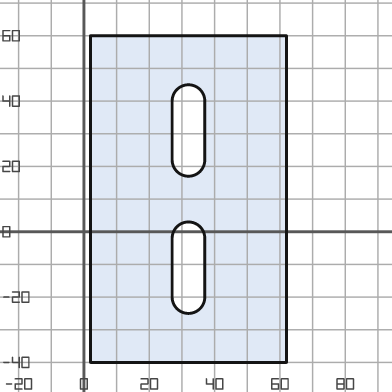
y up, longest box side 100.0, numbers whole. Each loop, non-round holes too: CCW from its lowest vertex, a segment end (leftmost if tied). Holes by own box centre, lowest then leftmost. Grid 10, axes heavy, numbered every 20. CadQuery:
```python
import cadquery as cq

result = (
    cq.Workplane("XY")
    .moveTo(2.0, -40.0)
    .lineTo(62.0, -40.0)
    .lineTo(62.0, 60.0)
    .lineTo(2.0, 60.0)
    .close()
    .moveTo(27.0, -20.0)
    .threePointArc((32.0, -25.0), (37.0, -20.0))
    .lineTo(37.0, -2.0)
    .threePointArc((32.0, 3.0), (27.0, -2.0))
    .close()
    .moveTo(27.0, 22.0)
    .threePointArc((32.0, 17.0), (37.0, 22.0))
    .lineTo(37.0, 40.0)
    .threePointArc((32.0, 45.0), (27.0, 40.0))
    .close()
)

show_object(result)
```